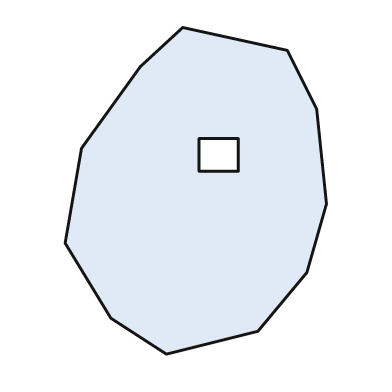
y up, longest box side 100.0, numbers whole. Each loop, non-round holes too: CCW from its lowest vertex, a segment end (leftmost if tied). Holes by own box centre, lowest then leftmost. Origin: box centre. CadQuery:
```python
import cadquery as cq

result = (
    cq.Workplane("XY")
    .moveTo(-9.0, -50.0)
    .lineTo(19.0, -43.0)
    .lineTo(34.0, -25.0)
    .lineTo(40.0, -4.0)
    .lineTo(37.0, 25.0)
    .lineTo(28.0, 43.0)
    .lineTo(-4.0, 50.0)
    .lineTo(-17.0, 38.0)
    .lineTo(-35.0, 13.0)
    .lineTo(-40.0, -16.0)
    .lineTo(-26.0, -39.0)
    .close()
    .moveTo(1.0, 6.0)
    .lineTo(13.0, 6.0)
    .lineTo(13.0, 16.0)
    .lineTo(1.0, 16.0)
    .close()
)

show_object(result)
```